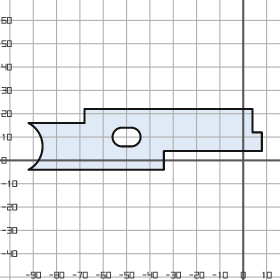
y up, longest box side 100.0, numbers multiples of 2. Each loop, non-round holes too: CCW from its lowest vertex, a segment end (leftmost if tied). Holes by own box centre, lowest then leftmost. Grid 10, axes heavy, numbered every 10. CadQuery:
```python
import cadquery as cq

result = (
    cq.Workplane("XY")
    .moveTo(-92.0, -4.0)
    .lineTo(-34.0, -4.0)
    .lineTo(-34.0, 4.0)
    .lineTo(8.0, 4.0)
    .lineTo(8.0, 12.0)
    .lineTo(4.0, 12.0)
    .lineTo(4.0, 22.0)
    .lineTo(-68.0, 22.0)
    .lineTo(-68.0, 16.0)
    .lineTo(-92.0, 16.0)
    .threePointArc((-86.0, 6.0), (-92.0, -4.0))
    .close()
    .moveTo(-52.0, 6.0)
    .lineTo(-48.0, 6.0)
    .threePointArc((-44.0, 10.0), (-48.0, 14.0))
    .lineTo(-52.0, 14.0)
    .threePointArc((-56.0, 10.0), (-52.0, 6.0))
    .close()
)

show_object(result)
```